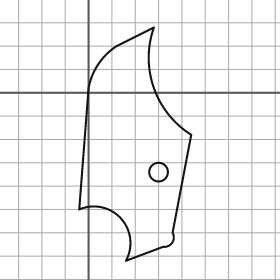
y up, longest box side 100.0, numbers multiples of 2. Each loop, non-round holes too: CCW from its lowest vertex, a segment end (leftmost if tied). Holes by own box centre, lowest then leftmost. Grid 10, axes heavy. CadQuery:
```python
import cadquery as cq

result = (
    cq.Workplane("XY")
    .moveTo(16.0, -72.0)
    .lineTo(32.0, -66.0)
    .threePointArc((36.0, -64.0), (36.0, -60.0))
    .lineTo(44.0, -18.0)
    .threePointArc((28.0, 2.0), (28.0, 28.0))
    .lineTo(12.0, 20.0)
    .threePointArc((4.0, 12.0), (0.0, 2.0))
    .lineTo(-4.0, -50.0)
    .threePointArc((14.0, -54.0), (16.0, -72.0))
    .close()
    .moveTo(30.0, -34.0)
    .circle(4.0)
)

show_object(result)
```